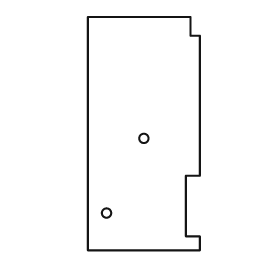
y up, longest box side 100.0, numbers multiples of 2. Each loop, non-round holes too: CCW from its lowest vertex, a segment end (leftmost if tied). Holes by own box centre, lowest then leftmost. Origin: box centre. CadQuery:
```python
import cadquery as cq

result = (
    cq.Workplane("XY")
    .moveTo(-24.0, -50.0)
    .lineTo(24.0, -50.0)
    .lineTo(24.0, -44.0)
    .lineTo(18.0, -44.0)
    .lineTo(18.0, -18.0)
    .lineTo(24.0, -18.0)
    .lineTo(24.0, 42.0)
    .lineTo(20.0, 42.0)
    .lineTo(20.0, 50.0)
    .lineTo(-24.0, 50.0)
    .close()
    .moveTo(-16.0, -34.0)
    .circle(2.0)
    .moveTo(0.0, -2.0)
    .circle(2.0)
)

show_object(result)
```